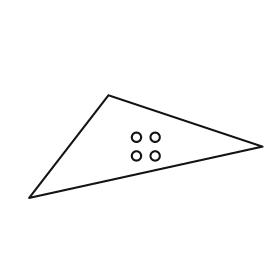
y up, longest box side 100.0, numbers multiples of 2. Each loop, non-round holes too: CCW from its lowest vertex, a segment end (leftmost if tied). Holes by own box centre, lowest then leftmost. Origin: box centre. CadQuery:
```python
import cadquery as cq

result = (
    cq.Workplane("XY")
    .moveTo(-50.0, -22.0)
    .lineTo(50.0, 0.0)
    .lineTo(-16.0, 22.0)
    .close()
    .moveTo(-4.0, -4.0)
    .circle(2.0)
    .moveTo(4.0, -4.0)
    .circle(2.0)
    .moveTo(-4.0, 4.0)
    .circle(2.0)
    .moveTo(4.0, 4.0)
    .circle(2.0)
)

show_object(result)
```